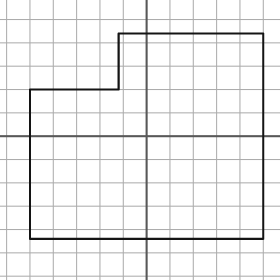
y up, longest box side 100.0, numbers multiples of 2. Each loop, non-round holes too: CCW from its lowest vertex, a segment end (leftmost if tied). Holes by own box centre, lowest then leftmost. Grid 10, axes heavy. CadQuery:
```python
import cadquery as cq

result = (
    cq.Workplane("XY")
    .moveTo(-50.0, -44.0)
    .lineTo(50.0, -44.0)
    .lineTo(50.0, 44.0)
    .lineTo(-12.0, 44.0)
    .lineTo(-12.0, 20.0)
    .lineTo(-50.0, 20.0)
    .close()
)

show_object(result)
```